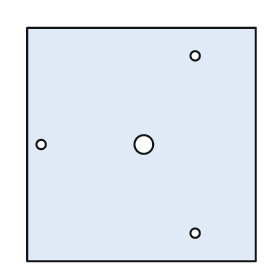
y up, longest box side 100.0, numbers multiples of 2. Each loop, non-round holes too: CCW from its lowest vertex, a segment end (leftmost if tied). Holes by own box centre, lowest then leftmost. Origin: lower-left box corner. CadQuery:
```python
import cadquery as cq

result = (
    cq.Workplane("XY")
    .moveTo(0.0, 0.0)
    .lineTo(98.0, 0.0)
    .lineTo(98.0, 100.0)
    .lineTo(0.0, 100.0)
    .close()
    .moveTo(72.0, 12.0)
    .circle(2.0)
    .moveTo(6.0, 50.0)
    .circle(2.0)
    .moveTo(50.0, 50.0)
    .circle(4.0)
    .moveTo(72.0, 88.0)
    .circle(2.0)
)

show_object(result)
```